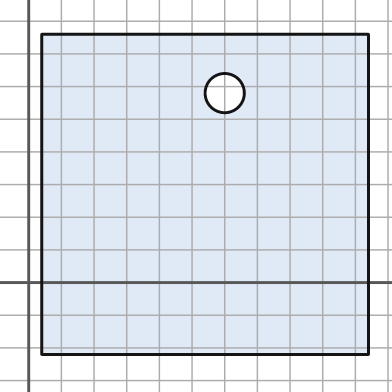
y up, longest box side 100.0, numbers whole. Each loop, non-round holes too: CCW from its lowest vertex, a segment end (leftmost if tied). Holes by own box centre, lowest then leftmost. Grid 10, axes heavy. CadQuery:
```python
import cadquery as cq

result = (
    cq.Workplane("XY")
    .moveTo(4.0, -22.0)
    .lineTo(104.0, -22.0)
    .lineTo(104.0, 76.0)
    .lineTo(4.0, 76.0)
    .close()
    .moveTo(60.0, 58.0)
    .circle(6.0)
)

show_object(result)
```